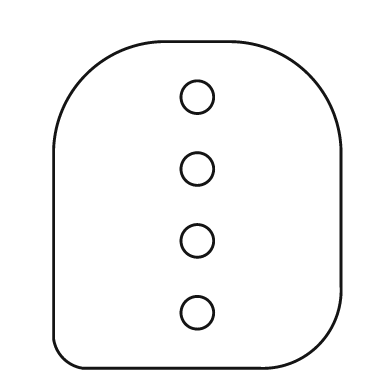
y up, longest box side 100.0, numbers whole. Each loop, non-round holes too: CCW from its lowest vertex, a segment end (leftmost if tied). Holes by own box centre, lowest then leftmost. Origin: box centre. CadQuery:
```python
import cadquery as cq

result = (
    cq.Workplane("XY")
    .moveTo(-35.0, -50.0)
    .lineTo(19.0, -50.0)
    .threePointArc((37.0, -43.0), (44.0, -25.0))
    .lineTo(44.0, 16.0)
    .threePointArc((34.0, 40.0), (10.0, 50.0))
    .lineTo(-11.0, 50.0)
    .threePointArc((-34.0, 40.0), (-44.0, 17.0))
    .lineTo(-44.0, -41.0)
    .threePointArc((-41.0, -47.0), (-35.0, -50.0))
    .close()
    .moveTo(0.0, -33.0)
    .circle(5.0)
    .moveTo(0.0, -11.0)
    .circle(5.0)
    .moveTo(0.0, 11.0)
    .circle(5.0)
    .moveTo(0.0, 33.0)
    .circle(5.0)
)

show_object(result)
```